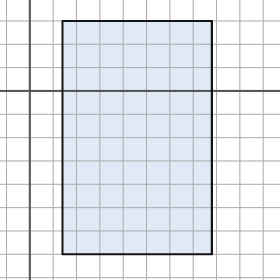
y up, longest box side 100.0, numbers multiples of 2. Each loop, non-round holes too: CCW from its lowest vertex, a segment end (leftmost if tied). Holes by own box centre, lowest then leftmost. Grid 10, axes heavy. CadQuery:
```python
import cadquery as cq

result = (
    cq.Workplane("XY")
    .moveTo(14.0, -70.0)
    .lineTo(78.0, -70.0)
    .lineTo(78.0, 30.0)
    .lineTo(14.0, 30.0)
    .close()
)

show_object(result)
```